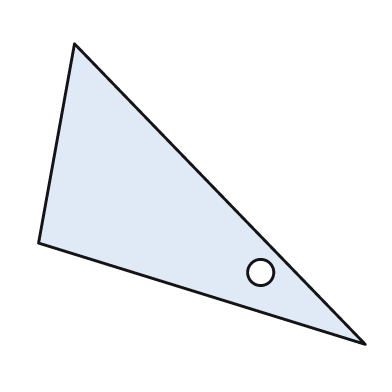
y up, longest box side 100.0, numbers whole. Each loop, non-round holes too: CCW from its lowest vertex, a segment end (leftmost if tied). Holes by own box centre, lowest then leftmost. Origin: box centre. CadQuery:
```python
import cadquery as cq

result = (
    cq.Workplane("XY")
    .moveTo(50.0, -46.0)
    .lineTo(-39.0, 46.0)
    .lineTo(-50.0, -15.0)
    .close()
    .moveTo(18.0, -24.0)
    .circle(4.0)
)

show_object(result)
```